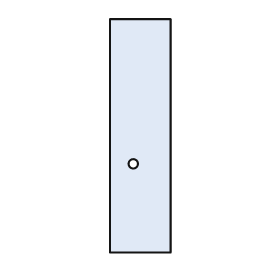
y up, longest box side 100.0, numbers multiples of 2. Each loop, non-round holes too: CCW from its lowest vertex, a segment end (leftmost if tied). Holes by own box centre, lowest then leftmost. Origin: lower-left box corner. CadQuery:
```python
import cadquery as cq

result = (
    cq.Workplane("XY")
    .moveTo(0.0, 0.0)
    .lineTo(26.0, 0.0)
    .lineTo(26.0, 100.0)
    .lineTo(0.0, 100.0)
    .close()
    .moveTo(10.0, 38.0)
    .circle(2.0)
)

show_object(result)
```